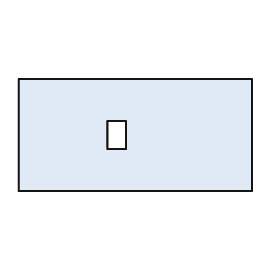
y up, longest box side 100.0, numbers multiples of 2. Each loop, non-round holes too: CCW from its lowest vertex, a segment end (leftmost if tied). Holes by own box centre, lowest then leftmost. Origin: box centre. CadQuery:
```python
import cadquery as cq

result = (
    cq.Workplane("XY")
    .moveTo(-50.0, -24.0)
    .lineTo(50.0, -24.0)
    .lineTo(50.0, 24.0)
    .lineTo(-50.0, 24.0)
    .close()
    .moveTo(-12.0, -6.0)
    .lineTo(-4.0, -6.0)
    .lineTo(-4.0, 6.0)
    .lineTo(-12.0, 6.0)
    .close()
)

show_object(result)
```